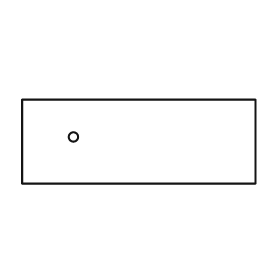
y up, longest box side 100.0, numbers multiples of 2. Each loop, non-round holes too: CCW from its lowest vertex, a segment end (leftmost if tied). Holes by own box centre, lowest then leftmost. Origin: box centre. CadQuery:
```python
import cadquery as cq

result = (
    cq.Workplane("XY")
    .moveTo(-50.0, -18.0)
    .lineTo(50.0, -18.0)
    .lineTo(50.0, 18.0)
    .lineTo(-50.0, 18.0)
    .close()
    .moveTo(-28.0, 2.0)
    .circle(2.0)
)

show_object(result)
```